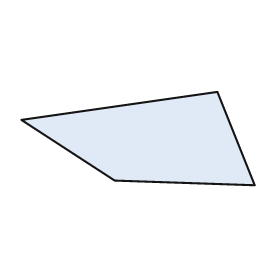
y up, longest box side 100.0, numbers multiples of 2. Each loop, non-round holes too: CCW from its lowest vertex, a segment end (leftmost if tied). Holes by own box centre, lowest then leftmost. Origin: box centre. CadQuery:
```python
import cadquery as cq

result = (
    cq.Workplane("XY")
    .moveTo(50.0, -20.0)
    .lineTo(34.0, 20.0)
    .lineTo(-50.0, 8.0)
    .lineTo(-10.0, -18.0)
    .close()
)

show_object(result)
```